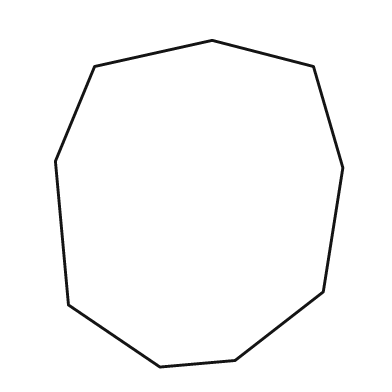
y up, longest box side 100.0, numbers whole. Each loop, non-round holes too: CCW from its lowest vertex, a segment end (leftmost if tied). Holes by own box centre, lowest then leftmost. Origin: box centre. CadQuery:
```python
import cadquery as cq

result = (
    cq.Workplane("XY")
    .moveTo(-12.0, -50.0)
    .lineTo(11.0, -48.0)
    .lineTo(38.0, -27.0)
    .lineTo(44.0, 11.0)
    .lineTo(35.0, 42.0)
    .lineTo(4.0, 50.0)
    .lineTo(-32.0, 42.0)
    .lineTo(-44.0, 13.0)
    .lineTo(-40.0, -31.0)
    .close()
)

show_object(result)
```